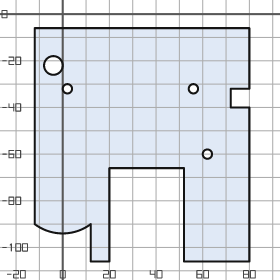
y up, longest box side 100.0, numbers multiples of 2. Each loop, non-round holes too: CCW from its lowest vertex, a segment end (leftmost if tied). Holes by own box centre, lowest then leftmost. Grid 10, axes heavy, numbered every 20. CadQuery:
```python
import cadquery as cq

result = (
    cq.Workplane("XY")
    .moveTo(12.0, -106.0)
    .lineTo(20.0, -106.0)
    .lineTo(20.0, -66.0)
    .lineTo(52.0, -66.0)
    .lineTo(52.0, -106.0)
    .lineTo(80.0, -106.0)
    .lineTo(80.0, -40.0)
    .lineTo(72.0, -40.0)
    .lineTo(72.0, -32.0)
    .lineTo(80.0, -32.0)
    .lineTo(80.0, -6.0)
    .lineTo(-12.0, -6.0)
    .lineTo(-12.0, -90.0)
    .threePointArc((0.0, -94.0), (12.0, -90.0))
    .close()
    .moveTo(62.0, -60.0)
    .circle(2.0)
    .moveTo(2.0, -32.0)
    .circle(2.0)
    .moveTo(56.0, -32.0)
    .circle(2.0)
    .moveTo(-4.0, -22.0)
    .circle(4.0)
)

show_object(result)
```